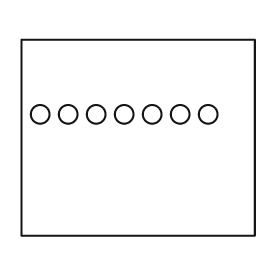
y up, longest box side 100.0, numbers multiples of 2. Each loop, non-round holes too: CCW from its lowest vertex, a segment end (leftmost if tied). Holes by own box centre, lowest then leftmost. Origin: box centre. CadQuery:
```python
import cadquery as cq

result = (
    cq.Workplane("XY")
    .moveTo(-50.0, -42.0)
    .lineTo(50.0, -42.0)
    .lineTo(50.0, 42.0)
    .lineTo(-50.0, 42.0)
    .close()
    .moveTo(-42.0, 10.0)
    .circle(4.0)
    .moveTo(-30.0, 10.0)
    .circle(4.0)
    .moveTo(-18.0, 10.0)
    .circle(4.0)
    .moveTo(-6.0, 10.0)
    .circle(4.0)
    .moveTo(6.0, 10.0)
    .circle(4.0)
    .moveTo(18.0, 10.0)
    .circle(4.0)
    .moveTo(30.0, 10.0)
    .circle(4.0)
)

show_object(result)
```